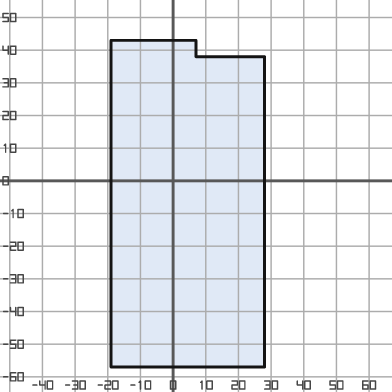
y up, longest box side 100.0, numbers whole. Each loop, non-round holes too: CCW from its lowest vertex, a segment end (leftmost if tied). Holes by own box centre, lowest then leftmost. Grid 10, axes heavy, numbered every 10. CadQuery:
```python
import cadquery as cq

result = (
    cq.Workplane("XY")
    .moveTo(-19.0, -57.0)
    .lineTo(28.0, -57.0)
    .lineTo(28.0, 38.0)
    .lineTo(7.0, 38.0)
    .lineTo(7.0, 43.0)
    .lineTo(-19.0, 43.0)
    .close()
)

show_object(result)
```